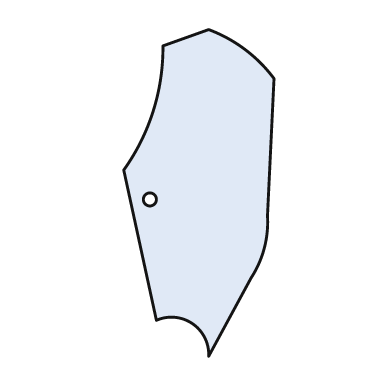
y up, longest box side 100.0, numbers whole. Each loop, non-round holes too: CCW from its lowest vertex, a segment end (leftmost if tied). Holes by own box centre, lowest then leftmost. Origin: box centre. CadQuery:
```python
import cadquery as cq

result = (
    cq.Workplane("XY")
    .moveTo(3.0, -50.0)
    .lineTo(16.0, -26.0)
    .threePointArc((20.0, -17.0), (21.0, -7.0))
    .lineTo(23.0, 35.0)
    .threePointArc((14.0, 44.0), (3.0, 50.0))
    .lineTo(-11.0, 45.0)
    .threePointArc((-14.0, 25.0), (-23.0, 7.0))
    .lineTo(-13.0, -39.0)
    .threePointArc((-2.0, -40.0), (3.0, -50.0))
    .close()
    .moveTo(-15.0, -2.0)
    .circle(2.0)
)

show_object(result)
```